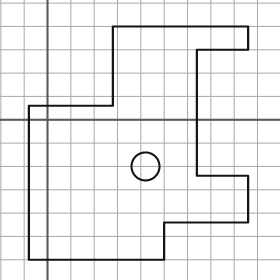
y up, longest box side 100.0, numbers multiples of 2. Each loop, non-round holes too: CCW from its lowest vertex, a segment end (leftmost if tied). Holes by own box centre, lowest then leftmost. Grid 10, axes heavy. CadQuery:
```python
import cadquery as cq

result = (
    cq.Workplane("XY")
    .moveTo(-8.0, -60.0)
    .lineTo(50.0, -60.0)
    .lineTo(50.0, -44.0)
    .lineTo(86.0, -44.0)
    .lineTo(86.0, -24.0)
    .lineTo(64.0, -24.0)
    .lineTo(64.0, 30.0)
    .lineTo(86.0, 30.0)
    .lineTo(86.0, 40.0)
    .lineTo(28.0, 40.0)
    .lineTo(28.0, 6.0)
    .lineTo(-8.0, 6.0)
    .close()
    .moveTo(42.0, -20.0)
    .circle(6.0)
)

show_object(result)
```